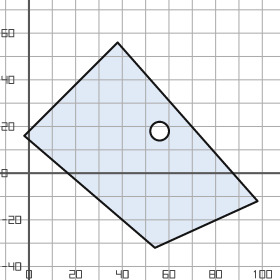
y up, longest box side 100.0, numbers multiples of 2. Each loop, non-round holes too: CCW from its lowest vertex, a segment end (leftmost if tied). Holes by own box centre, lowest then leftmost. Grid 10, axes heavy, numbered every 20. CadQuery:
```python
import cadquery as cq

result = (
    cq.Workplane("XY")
    .moveTo(54.0, -32.0)
    .lineTo(98.0, -12.0)
    .lineTo(38.0, 56.0)
    .lineTo(-2.0, 16.0)
    .close()
    .moveTo(56.0, 18.0)
    .circle(4.0)
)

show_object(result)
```